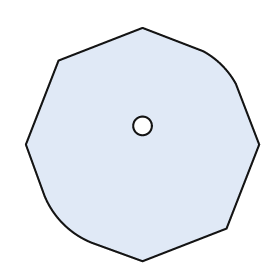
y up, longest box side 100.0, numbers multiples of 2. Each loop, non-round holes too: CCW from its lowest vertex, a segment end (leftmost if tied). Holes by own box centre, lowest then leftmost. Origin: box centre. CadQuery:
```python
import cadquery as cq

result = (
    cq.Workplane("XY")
    .moveTo(0.0, -50.0)
    .lineTo(36.0, -36.0)
    .lineTo(50.0, 0.0)
    .lineTo(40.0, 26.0)
    .threePointArc((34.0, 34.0), (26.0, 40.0))
    .lineTo(0.0, 50.0)
    .lineTo(-36.0, 36.0)
    .lineTo(-50.0, 0.0)
    .lineTo(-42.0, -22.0)
    .threePointArc((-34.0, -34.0), (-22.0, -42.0))
    .close()
    .moveTo(0.0, 8.0)
    .circle(4.0)
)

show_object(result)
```